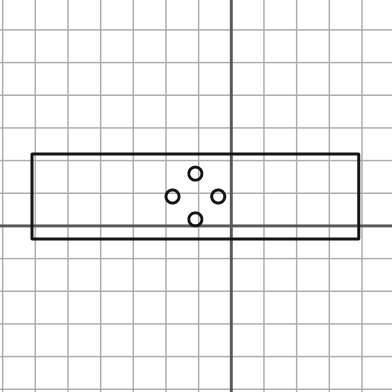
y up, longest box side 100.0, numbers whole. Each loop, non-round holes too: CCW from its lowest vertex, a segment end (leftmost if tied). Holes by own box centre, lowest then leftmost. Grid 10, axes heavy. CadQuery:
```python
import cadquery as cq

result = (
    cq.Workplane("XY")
    .moveTo(-61.0, -4.0)
    .lineTo(39.0, -4.0)
    .lineTo(39.0, 22.0)
    .lineTo(-61.0, 22.0)
    .close()
    .moveTo(-11.0, 2.0)
    .circle(2.0)
    .moveTo(-18.0, 9.0)
    .circle(2.0)
    .moveTo(-4.0, 9.0)
    .circle(2.0)
    .moveTo(-11.0, 16.0)
    .circle(2.0)
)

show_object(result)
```